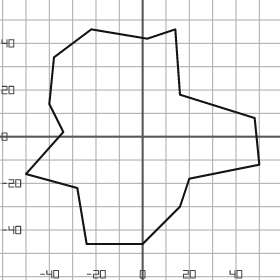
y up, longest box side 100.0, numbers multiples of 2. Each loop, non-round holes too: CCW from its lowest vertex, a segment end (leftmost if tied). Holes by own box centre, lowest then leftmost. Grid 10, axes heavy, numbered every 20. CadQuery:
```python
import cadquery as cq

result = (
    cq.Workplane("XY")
    .moveTo(-24.0, -46.0)
    .lineTo(0.0, -46.0)
    .lineTo(16.0, -30.0)
    .lineTo(20.0, -18.0)
    .lineTo(50.0, -12.0)
    .lineTo(48.0, 8.0)
    .lineTo(16.0, 18.0)
    .lineTo(14.0, 46.0)
    .lineTo(2.0, 42.0)
    .lineTo(-22.0, 46.0)
    .lineTo(-38.0, 34.0)
    .lineTo(-40.0, 14.0)
    .lineTo(-34.0, 2.0)
    .lineTo(-50.0, -16.0)
    .lineTo(-28.0, -22.0)
    .close()
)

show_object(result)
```